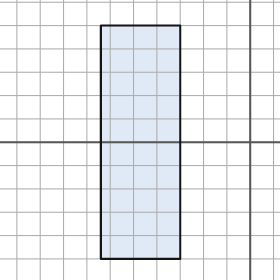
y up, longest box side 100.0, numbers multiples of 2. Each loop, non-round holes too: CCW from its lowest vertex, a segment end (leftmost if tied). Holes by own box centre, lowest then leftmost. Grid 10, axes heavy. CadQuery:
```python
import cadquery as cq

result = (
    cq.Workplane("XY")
    .moveTo(-64.0, -50.0)
    .lineTo(-30.0, -50.0)
    .lineTo(-30.0, 50.0)
    .lineTo(-64.0, 50.0)
    .close()
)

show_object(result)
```